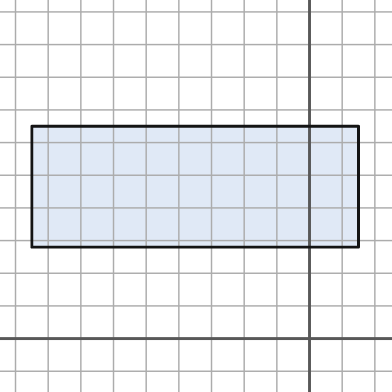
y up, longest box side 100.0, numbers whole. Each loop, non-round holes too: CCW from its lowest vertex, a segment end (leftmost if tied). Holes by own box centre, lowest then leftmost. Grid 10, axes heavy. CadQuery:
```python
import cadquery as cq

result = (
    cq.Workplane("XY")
    .moveTo(-85.0, 28.0)
    .lineTo(15.0, 28.0)
    .lineTo(15.0, 65.0)
    .lineTo(-85.0, 65.0)
    .close()
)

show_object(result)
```